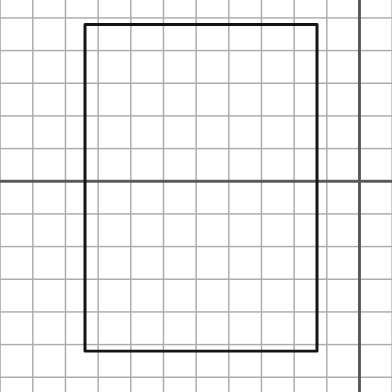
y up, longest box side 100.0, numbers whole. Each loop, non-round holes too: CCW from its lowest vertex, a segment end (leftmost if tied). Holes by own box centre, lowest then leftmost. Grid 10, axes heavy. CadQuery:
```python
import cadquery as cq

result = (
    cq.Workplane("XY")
    .moveTo(-84.0, -52.0)
    .lineTo(-13.0, -52.0)
    .lineTo(-13.0, 48.0)
    .lineTo(-84.0, 48.0)
    .close()
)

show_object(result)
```